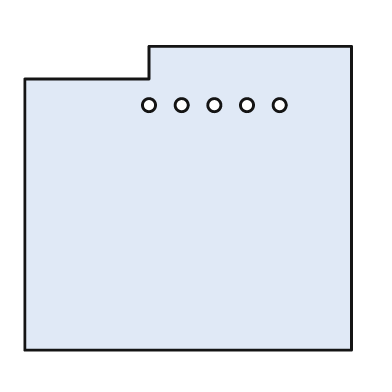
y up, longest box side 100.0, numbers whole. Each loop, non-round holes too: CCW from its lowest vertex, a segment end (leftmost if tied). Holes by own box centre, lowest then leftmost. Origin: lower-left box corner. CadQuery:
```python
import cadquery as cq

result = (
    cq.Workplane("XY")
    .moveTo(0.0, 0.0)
    .lineTo(100.0, 0.0)
    .lineTo(100.0, 93.0)
    .lineTo(38.0, 93.0)
    .lineTo(38.0, 83.0)
    .lineTo(0.0, 83.0)
    .close()
    .moveTo(38.0, 75.0)
    .circle(2.0)
    .moveTo(48.0, 75.0)
    .circle(2.0)
    .moveTo(58.0, 75.0)
    .circle(2.0)
    .moveTo(68.0, 75.0)
    .circle(2.0)
    .moveTo(78.0, 75.0)
    .circle(2.0)
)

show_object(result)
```